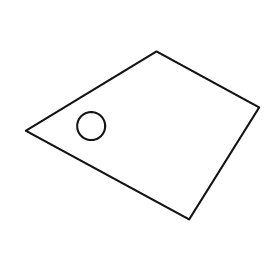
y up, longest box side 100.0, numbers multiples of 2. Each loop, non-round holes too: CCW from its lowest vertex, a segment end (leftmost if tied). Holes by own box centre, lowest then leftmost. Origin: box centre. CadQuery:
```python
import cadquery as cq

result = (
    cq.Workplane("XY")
    .moveTo(20.0, -36.0)
    .lineTo(50.0, 12.0)
    .lineTo(6.0, 36.0)
    .lineTo(-50.0, 2.0)
    .close()
    .moveTo(-22.0, 4.0)
    .circle(6.0)
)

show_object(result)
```